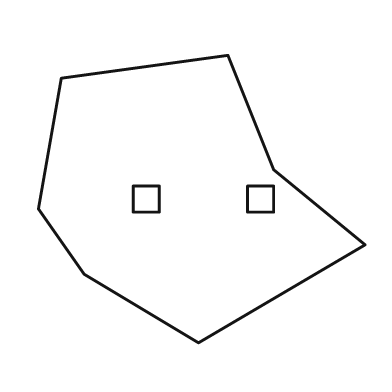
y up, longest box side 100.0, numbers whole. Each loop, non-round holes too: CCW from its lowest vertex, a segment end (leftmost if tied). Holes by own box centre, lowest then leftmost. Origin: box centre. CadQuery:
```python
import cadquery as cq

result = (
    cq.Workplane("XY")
    .moveTo(-1.0, -44.0)
    .lineTo(50.0, -14.0)
    .lineTo(22.0, 9.0)
    .lineTo(8.0, 44.0)
    .lineTo(-43.0, 37.0)
    .lineTo(-50.0, -3.0)
    .lineTo(-36.0, -23.0)
    .close()
    .moveTo(-21.0, -4.0)
    .lineTo(-13.0, -4.0)
    .lineTo(-13.0, 4.0)
    .lineTo(-21.0, 4.0)
    .close()
    .moveTo(14.0, -4.0)
    .lineTo(22.0, -4.0)
    .lineTo(22.0, 4.0)
    .lineTo(14.0, 4.0)
    .close()
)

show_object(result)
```